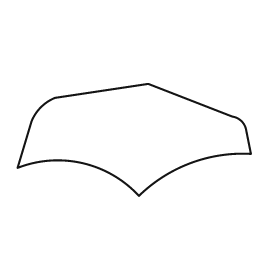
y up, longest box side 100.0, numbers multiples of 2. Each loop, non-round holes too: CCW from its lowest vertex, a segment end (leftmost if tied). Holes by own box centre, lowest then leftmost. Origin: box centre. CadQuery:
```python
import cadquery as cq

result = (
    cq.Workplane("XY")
    .moveTo(2.0, -24.0)
    .threePointArc((24.0, -10.0), (50.0, -6.0))
    .lineTo(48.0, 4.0)
    .threePointArc((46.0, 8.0), (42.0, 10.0))
    .lineTo(6.0, 24.0)
    .lineTo(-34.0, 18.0)
    .threePointArc((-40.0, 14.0), (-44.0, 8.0))
    .lineTo(-50.0, -12.0)
    .threePointArc((-22.0, -10.0), (2.0, -24.0))
    .close()
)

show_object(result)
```